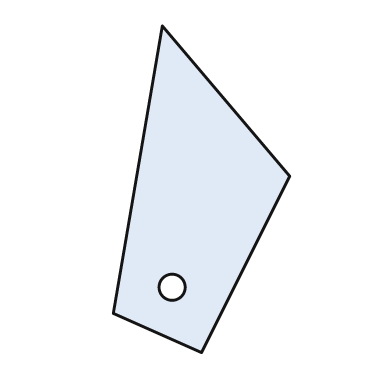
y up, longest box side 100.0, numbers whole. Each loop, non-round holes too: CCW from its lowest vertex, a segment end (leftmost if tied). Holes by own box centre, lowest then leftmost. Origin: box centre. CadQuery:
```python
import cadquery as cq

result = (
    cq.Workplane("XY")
    .moveTo(0.0, -50.0)
    .lineTo(27.0, 4.0)
    .lineTo(-12.0, 50.0)
    .lineTo(-27.0, -38.0)
    .close()
    .moveTo(-9.0, -30.0)
    .circle(4.0)
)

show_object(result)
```